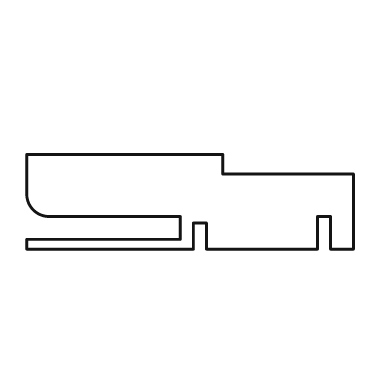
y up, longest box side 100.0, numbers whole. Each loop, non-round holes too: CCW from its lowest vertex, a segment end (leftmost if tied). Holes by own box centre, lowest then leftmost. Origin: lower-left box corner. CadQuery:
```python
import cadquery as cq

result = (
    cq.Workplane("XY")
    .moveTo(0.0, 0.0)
    .lineTo(51.0, 0.0)
    .lineTo(51.0, 8.0)
    .lineTo(55.0, 8.0)
    .lineTo(55.0, 0.0)
    .lineTo(89.0, 0.0)
    .lineTo(89.0, 10.0)
    .lineTo(93.0, 10.0)
    .lineTo(93.0, 0.0)
    .lineTo(100.0, 0.0)
    .lineTo(100.0, 23.0)
    .lineTo(60.0, 23.0)
    .lineTo(60.0, 29.0)
    .lineTo(0.0, 29.0)
    .lineTo(0.0, 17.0)
    .threePointArc((2.0, 12.0), (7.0, 10.0))
    .lineTo(47.0, 10.0)
    .lineTo(47.0, 3.0)
    .lineTo(0.0, 3.0)
    .close()
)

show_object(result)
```